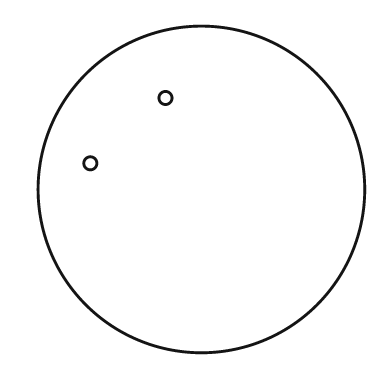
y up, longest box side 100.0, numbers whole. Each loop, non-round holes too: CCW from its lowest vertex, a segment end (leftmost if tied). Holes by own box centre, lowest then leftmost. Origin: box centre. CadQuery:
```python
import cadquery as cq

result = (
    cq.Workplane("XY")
    .moveTo(0.0, 0.0)
    .circle(50.0)
    .moveTo(-34.0, 8.0)
    .circle(2.0)
    .moveTo(-11.0, 28.0)
    .circle(2.0)
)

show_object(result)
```